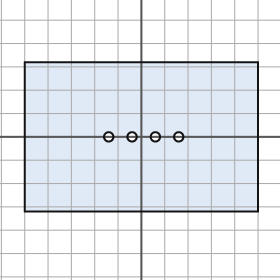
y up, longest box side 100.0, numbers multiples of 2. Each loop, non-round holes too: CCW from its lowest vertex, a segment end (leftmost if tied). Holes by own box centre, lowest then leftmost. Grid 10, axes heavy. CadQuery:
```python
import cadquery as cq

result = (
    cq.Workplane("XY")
    .moveTo(-50.0, -32.0)
    .lineTo(50.0, -32.0)
    .lineTo(50.0, 32.0)
    .lineTo(-50.0, 32.0)
    .close()
    .moveTo(-14.0, 0.0)
    .circle(2.0)
    .moveTo(-4.0, 0.0)
    .circle(2.0)
    .moveTo(6.0, 0.0)
    .circle(2.0)
    .moveTo(16.0, 0.0)
    .circle(2.0)
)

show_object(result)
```